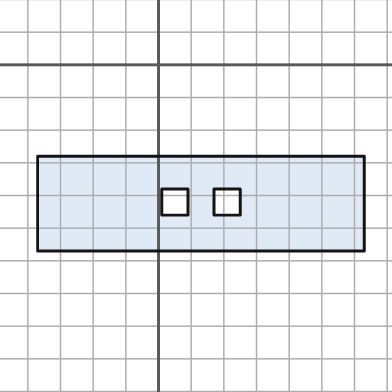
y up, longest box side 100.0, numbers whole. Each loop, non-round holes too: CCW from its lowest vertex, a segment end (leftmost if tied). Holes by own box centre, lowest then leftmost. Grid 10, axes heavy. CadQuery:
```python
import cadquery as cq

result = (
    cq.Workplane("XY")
    .moveTo(-37.0, -57.0)
    .lineTo(63.0, -57.0)
    .lineTo(63.0, -28.0)
    .lineTo(-37.0, -28.0)
    .close()
    .moveTo(1.0, -46.0)
    .lineTo(9.0, -46.0)
    .lineTo(9.0, -38.0)
    .lineTo(1.0, -38.0)
    .close()
    .moveTo(17.0, -46.0)
    .lineTo(25.0, -46.0)
    .lineTo(25.0, -38.0)
    .lineTo(17.0, -38.0)
    .close()
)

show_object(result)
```